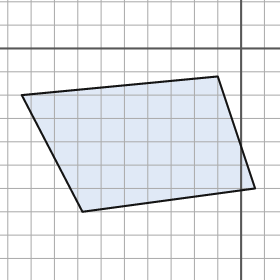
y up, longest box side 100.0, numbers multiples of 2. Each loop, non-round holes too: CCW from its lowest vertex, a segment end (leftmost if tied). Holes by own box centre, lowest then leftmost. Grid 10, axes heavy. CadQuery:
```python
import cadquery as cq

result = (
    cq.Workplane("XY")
    .moveTo(-68.0, -70.0)
    .lineTo(6.0, -60.0)
    .lineTo(-10.0, -12.0)
    .lineTo(-94.0, -20.0)
    .close()
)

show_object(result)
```